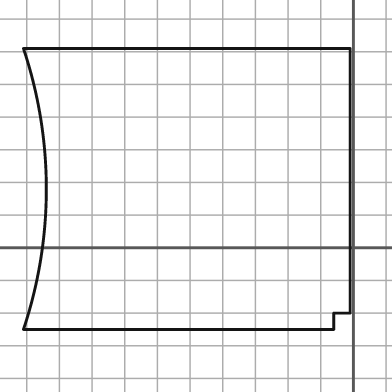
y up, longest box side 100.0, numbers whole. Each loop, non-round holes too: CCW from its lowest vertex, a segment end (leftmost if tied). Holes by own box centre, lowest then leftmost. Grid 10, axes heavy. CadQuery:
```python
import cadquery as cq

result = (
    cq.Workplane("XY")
    .moveTo(-101.0, -25.0)
    .lineTo(-6.0, -25.0)
    .lineTo(-6.0, -20.0)
    .lineTo(-1.0, -20.0)
    .lineTo(-1.0, 61.0)
    .lineTo(-101.0, 61.0)
    .threePointArc((-94.0, 18.0), (-101.0, -25.0))
    .close()
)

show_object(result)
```